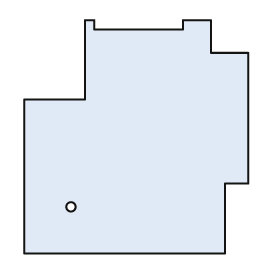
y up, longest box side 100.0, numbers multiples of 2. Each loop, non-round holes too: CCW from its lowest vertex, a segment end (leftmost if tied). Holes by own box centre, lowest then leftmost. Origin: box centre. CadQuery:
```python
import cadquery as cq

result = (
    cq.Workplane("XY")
    .moveTo(-48.0, -50.0)
    .lineTo(38.0, -50.0)
    .lineTo(38.0, -20.0)
    .lineTo(48.0, -20.0)
    .lineTo(48.0, 36.0)
    .lineTo(32.0, 36.0)
    .lineTo(32.0, 50.0)
    .lineTo(20.0, 50.0)
    .lineTo(20.0, 46.0)
    .lineTo(-18.0, 46.0)
    .lineTo(-18.0, 50.0)
    .lineTo(-22.0, 50.0)
    .lineTo(-22.0, 16.0)
    .lineTo(-48.0, 16.0)
    .close()
    .moveTo(-28.0, -30.0)
    .circle(2.0)
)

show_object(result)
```